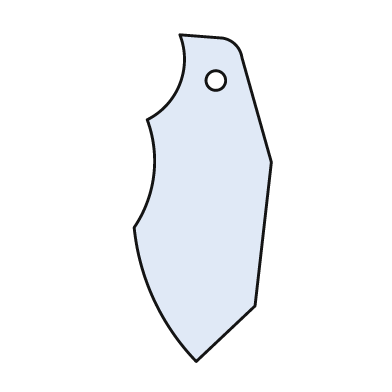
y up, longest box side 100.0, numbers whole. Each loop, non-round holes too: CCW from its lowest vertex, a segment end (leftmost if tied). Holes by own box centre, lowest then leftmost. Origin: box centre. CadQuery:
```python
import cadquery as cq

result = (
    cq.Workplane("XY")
    .moveTo(-2.0, -50.0)
    .lineTo(16.0, -33.0)
    .lineTo(21.0, 11.0)
    .lineTo(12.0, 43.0)
    .threePointArc((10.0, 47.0), (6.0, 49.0))
    .lineTo(-7.0, 50.0)
    .threePointArc((-7.0, 35.0), (-17.0, 24.0))
    .threePointArc((-15.0, 7.0), (-21.0, -9.0))
    .threePointArc((-15.0, -31.0), (-2.0, -50.0))
    .close()
    .moveTo(4.0, 36.0)
    .circle(3.0)
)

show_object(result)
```